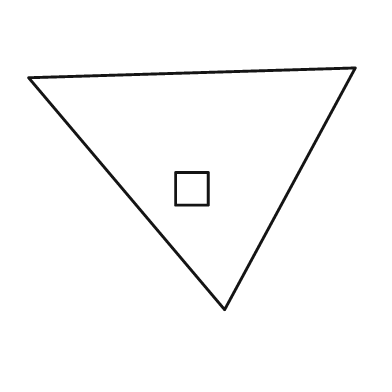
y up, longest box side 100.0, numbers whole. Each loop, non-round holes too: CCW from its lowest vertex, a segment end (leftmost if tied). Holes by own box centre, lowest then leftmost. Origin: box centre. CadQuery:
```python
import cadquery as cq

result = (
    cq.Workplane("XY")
    .moveTo(10.0, -37.0)
    .lineTo(50.0, 37.0)
    .lineTo(-50.0, 34.0)
    .close()
    .moveTo(-5.0, -5.0)
    .lineTo(5.0, -5.0)
    .lineTo(5.0, 5.0)
    .lineTo(-5.0, 5.0)
    .close()
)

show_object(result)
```